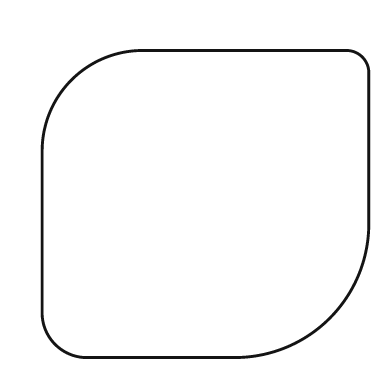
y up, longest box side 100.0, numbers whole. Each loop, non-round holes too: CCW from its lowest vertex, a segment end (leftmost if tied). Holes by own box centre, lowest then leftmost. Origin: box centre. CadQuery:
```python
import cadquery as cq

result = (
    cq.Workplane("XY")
    .moveTo(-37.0, -47.0)
    .lineTo(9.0, -47.0)
    .threePointArc((38.0, -35.0), (50.0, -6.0))
    .lineTo(50.0, 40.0)
    .threePointArc((48.0, 45.0), (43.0, 47.0))
    .lineTo(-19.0, 47.0)
    .threePointArc((-41.0, 38.0), (-50.0, 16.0))
    .lineTo(-50.0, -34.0)
    .threePointArc((-46.0, -43.0), (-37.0, -47.0))
    .close()
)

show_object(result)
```